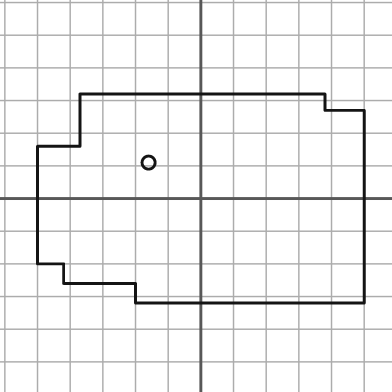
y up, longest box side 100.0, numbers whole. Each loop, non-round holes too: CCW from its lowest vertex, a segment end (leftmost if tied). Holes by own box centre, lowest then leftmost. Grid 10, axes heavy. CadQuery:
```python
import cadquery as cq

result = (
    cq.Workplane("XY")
    .moveTo(-20.0, -32.0)
    .lineTo(50.0, -32.0)
    .lineTo(50.0, 27.0)
    .lineTo(38.0, 27.0)
    .lineTo(38.0, 32.0)
    .lineTo(-37.0, 32.0)
    .lineTo(-37.0, 16.0)
    .lineTo(-50.0, 16.0)
    .lineTo(-50.0, -20.0)
    .lineTo(-42.0, -20.0)
    .lineTo(-42.0, -26.0)
    .lineTo(-20.0, -26.0)
    .close()
    .moveTo(-16.0, 11.0)
    .circle(2.0)
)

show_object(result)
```